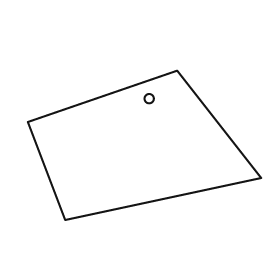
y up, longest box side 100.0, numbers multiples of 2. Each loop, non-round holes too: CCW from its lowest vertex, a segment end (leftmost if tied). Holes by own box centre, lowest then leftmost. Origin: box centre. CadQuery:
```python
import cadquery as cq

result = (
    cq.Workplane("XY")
    .moveTo(-34.0, -32.0)
    .lineTo(50.0, -14.0)
    .lineTo(14.0, 32.0)
    .lineTo(-50.0, 10.0)
    .close()
    .moveTo(2.0, 20.0)
    .circle(2.0)
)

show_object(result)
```